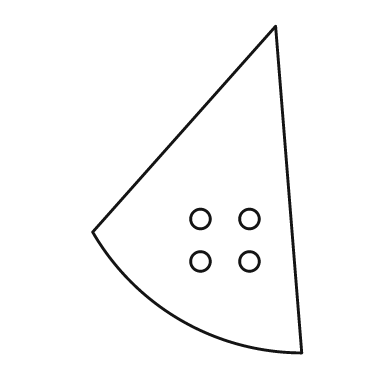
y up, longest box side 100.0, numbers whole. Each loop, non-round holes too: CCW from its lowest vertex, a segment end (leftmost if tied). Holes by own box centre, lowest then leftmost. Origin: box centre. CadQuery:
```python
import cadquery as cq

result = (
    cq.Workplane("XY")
    .moveTo(32.0, -50.0)
    .lineTo(24.0, 50.0)
    .lineTo(-32.0, -13.0)
    .threePointArc((-5.0, -40.0), (32.0, -50.0))
    .close()
    .moveTo(1.0, -22.0)
    .circle(3.0)
    .moveTo(16.0, -22.0)
    .circle(3.0)
    .moveTo(1.0, -9.0)
    .circle(3.0)
    .moveTo(16.0, -9.0)
    .circle(3.0)
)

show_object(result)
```